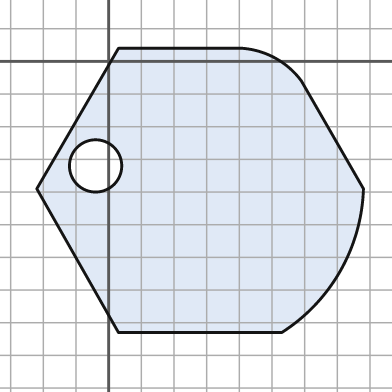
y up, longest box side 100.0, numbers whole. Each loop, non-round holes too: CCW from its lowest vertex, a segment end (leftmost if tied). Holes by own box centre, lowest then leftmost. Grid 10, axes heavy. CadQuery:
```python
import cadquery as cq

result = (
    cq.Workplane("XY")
    .moveTo(3.0, -83.0)
    .lineTo(53.0, -83.0)
    .threePointArc((71.0, -64.0), (78.0, -39.0))
    .lineTo(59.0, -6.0)
    .threePointArc((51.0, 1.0), (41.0, 4.0))
    .lineTo(3.0, 4.0)
    .lineTo(-22.0, -39.0)
    .close()
    .moveTo(-4.0, -32.0)
    .circle(8.0)
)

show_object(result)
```